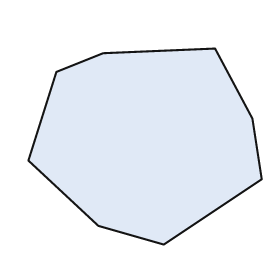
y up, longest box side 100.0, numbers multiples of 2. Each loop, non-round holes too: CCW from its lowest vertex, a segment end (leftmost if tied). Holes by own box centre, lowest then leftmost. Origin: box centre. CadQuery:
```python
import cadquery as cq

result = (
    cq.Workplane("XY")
    .moveTo(8.0, -42.0)
    .lineTo(50.0, -14.0)
    .lineTo(46.0, 12.0)
    .lineTo(30.0, 42.0)
    .lineTo(-18.0, 40.0)
    .lineTo(-38.0, 32.0)
    .lineTo(-50.0, -6.0)
    .lineTo(-20.0, -34.0)
    .close()
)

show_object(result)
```